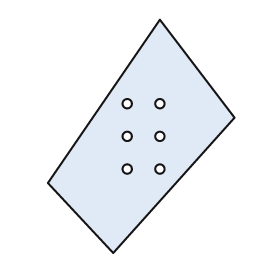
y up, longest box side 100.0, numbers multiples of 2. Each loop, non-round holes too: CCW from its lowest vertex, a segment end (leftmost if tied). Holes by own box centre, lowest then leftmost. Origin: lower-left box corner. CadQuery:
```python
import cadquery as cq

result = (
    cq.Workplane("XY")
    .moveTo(28.0, 0.0)
    .lineTo(80.0, 58.0)
    .lineTo(48.0, 100.0)
    .lineTo(0.0, 30.0)
    .close()
    .moveTo(34.0, 36.0)
    .circle(2.0)
    .moveTo(48.0, 36.0)
    .circle(2.0)
    .moveTo(34.0, 50.0)
    .circle(2.0)
    .moveTo(48.0, 50.0)
    .circle(2.0)
    .moveTo(34.0, 64.0)
    .circle(2.0)
    .moveTo(48.0, 64.0)
    .circle(2.0)
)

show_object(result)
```